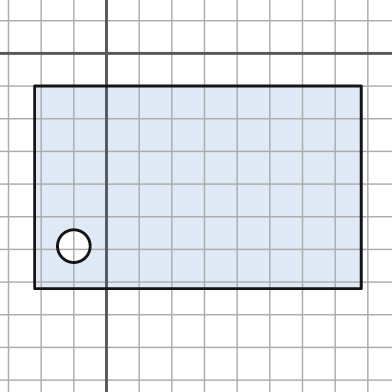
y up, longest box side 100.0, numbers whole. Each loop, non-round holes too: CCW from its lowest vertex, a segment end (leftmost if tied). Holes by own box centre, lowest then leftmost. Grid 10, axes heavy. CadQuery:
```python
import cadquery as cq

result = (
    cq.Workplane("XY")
    .moveTo(-22.0, -72.0)
    .lineTo(78.0, -72.0)
    .lineTo(78.0, -10.0)
    .lineTo(-22.0, -10.0)
    .close()
    .moveTo(-10.0, -59.0)
    .circle(5.0)
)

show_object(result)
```